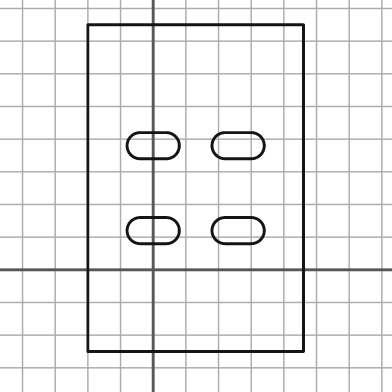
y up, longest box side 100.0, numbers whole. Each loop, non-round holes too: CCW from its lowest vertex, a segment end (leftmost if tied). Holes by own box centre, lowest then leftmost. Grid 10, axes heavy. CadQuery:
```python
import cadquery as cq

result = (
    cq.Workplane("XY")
    .moveTo(-20.0, -25.0)
    .lineTo(46.0, -25.0)
    .lineTo(46.0, 75.0)
    .lineTo(-20.0, 75.0)
    .close()
    .moveTo(-4.0, 8.0)
    .lineTo(4.0, 8.0)
    .threePointArc((8.0, 12.0), (4.0, 16.0))
    .lineTo(-4.0, 16.0)
    .threePointArc((-8.0, 12.0), (-4.0, 8.0))
    .close()
    .moveTo(22.0, 8.0)
    .lineTo(30.0, 8.0)
    .threePointArc((34.0, 12.0), (30.0, 16.0))
    .lineTo(22.0, 16.0)
    .threePointArc((18.0, 12.0), (22.0, 8.0))
    .close()
    .moveTo(-4.0, 34.0)
    .lineTo(4.0, 34.0)
    .threePointArc((8.0, 38.0), (4.0, 42.0))
    .lineTo(-4.0, 42.0)
    .threePointArc((-8.0, 38.0), (-4.0, 34.0))
    .close()
    .moveTo(22.0, 34.0)
    .lineTo(30.0, 34.0)
    .threePointArc((34.0, 38.0), (30.0, 42.0))
    .lineTo(22.0, 42.0)
    .threePointArc((18.0, 38.0), (22.0, 34.0))
    .close()
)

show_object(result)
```